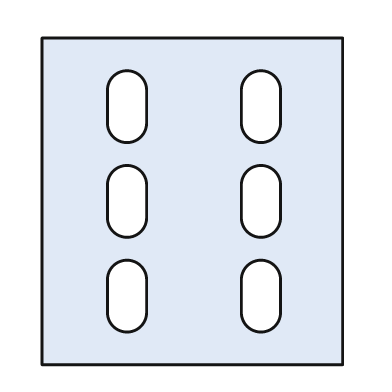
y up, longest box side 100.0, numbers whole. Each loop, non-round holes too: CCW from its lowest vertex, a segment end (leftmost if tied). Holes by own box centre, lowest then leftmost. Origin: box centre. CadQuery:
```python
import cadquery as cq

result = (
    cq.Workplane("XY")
    .moveTo(-46.0, -50.0)
    .lineTo(46.0, -50.0)
    .lineTo(46.0, 50.0)
    .lineTo(-46.0, 50.0)
    .close()
    .moveTo(-26.0, -34.0)
    .threePointArc((-20.0, -40.0), (-14.0, -34.0))
    .lineTo(-14.0, -24.0)
    .threePointArc((-20.0, -18.0), (-26.0, -24.0))
    .close()
    .moveTo(15.0, -34.0)
    .threePointArc((21.0, -40.0), (27.0, -34.0))
    .lineTo(27.0, -24.0)
    .threePointArc((21.0, -18.0), (15.0, -24.0))
    .close()
    .moveTo(-26.0, -5.0)
    .threePointArc((-20.0, -11.0), (-14.0, -5.0))
    .lineTo(-14.0, 5.0)
    .threePointArc((-20.0, 11.0), (-26.0, 5.0))
    .close()
    .moveTo(15.0, -5.0)
    .threePointArc((21.0, -11.0), (27.0, -5.0))
    .lineTo(27.0, 5.0)
    .threePointArc((21.0, 11.0), (15.0, 5.0))
    .close()
    .moveTo(-26.0, 24.0)
    .threePointArc((-20.0, 18.0), (-14.0, 24.0))
    .lineTo(-14.0, 34.0)
    .threePointArc((-20.0, 40.0), (-26.0, 34.0))
    .close()
    .moveTo(15.0, 24.0)
    .threePointArc((21.0, 18.0), (27.0, 24.0))
    .lineTo(27.0, 34.0)
    .threePointArc((21.0, 40.0), (15.0, 34.0))
    .close()
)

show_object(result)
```